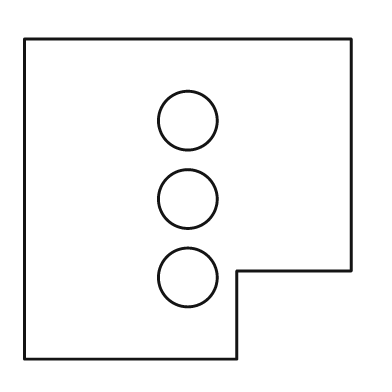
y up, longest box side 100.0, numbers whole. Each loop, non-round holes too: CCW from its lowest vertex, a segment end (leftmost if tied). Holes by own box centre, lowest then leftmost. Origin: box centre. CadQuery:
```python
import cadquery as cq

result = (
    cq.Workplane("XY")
    .moveTo(-50.0, -49.0)
    .lineTo(15.0, -49.0)
    .lineTo(15.0, -22.0)
    .lineTo(50.0, -22.0)
    .lineTo(50.0, 49.0)
    .lineTo(-50.0, 49.0)
    .close()
    .moveTo(0.0, -24.0)
    .circle(9.0)
    .moveTo(0.0, 0.0)
    .circle(9.0)
    .moveTo(0.0, 24.0)
    .circle(9.0)
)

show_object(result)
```